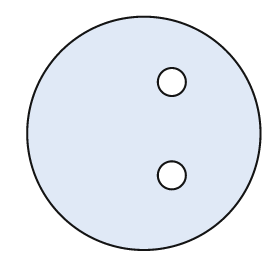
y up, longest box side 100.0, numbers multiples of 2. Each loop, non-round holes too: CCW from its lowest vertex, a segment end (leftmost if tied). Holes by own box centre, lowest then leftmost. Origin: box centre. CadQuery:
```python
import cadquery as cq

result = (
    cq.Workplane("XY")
    .moveTo(0.0, 0.0)
    .circle(50.0)
    .moveTo(12.0, -18.0)
    .circle(6.0)
    .moveTo(12.0, 22.0)
    .circle(6.0)
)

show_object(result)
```